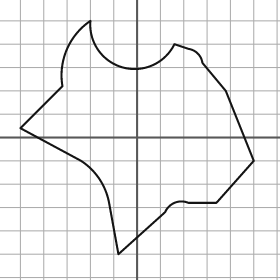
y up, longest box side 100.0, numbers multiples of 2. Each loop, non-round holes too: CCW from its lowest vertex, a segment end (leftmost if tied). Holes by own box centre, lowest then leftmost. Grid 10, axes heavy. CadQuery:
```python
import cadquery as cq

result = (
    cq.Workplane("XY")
    .moveTo(-8.0, -50.0)
    .lineTo(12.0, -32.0)
    .threePointArc((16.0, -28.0), (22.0, -28.0))
    .lineTo(34.0, -28.0)
    .lineTo(50.0, -10.0)
    .lineTo(38.0, 20.0)
    .lineTo(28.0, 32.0)
    .threePointArc((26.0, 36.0), (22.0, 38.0))
    .lineTo(16.0, 40.0)
    .threePointArc((-6.0, 30.0), (-20.0, 50.0))
    .threePointArc((-30.0, 38.0), (-32.0, 22.0))
    .lineTo(-50.0, 4.0)
    .lineTo(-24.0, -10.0)
    .threePointArc((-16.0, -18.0), (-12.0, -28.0))
    .close()
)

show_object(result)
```